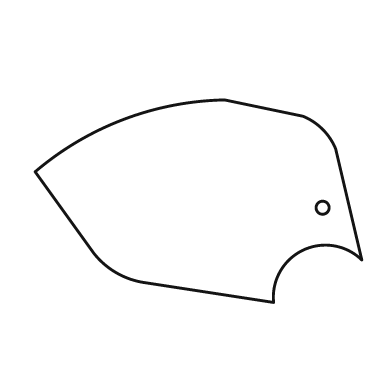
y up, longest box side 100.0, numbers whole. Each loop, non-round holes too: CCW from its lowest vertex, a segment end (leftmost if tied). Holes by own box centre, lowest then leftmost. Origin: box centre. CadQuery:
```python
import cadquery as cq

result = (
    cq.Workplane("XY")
    .moveTo(23.0, -31.0)
    .threePointArc((32.0, -15.0), (50.0, -18.0))
    .lineTo(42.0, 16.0)
    .threePointArc((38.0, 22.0), (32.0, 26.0))
    .lineTo(8.0, 31.0)
    .threePointArc((-23.0, 25.0), (-50.0, 9.0))
    .lineTo(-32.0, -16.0)
    .threePointArc((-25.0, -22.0), (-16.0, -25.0))
    .close()
    .moveTo(38.0, -2.0)
    .circle(2.0)
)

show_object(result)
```